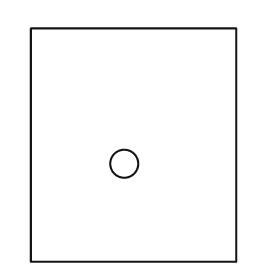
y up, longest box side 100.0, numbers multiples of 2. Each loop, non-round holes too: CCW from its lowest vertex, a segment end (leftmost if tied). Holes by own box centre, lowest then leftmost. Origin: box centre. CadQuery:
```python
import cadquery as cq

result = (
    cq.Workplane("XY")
    .moveTo(-44.0, -50.0)
    .lineTo(44.0, -50.0)
    .lineTo(44.0, 50.0)
    .lineTo(-44.0, 50.0)
    .close()
    .moveTo(-4.0, -8.0)
    .circle(6.0)
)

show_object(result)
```